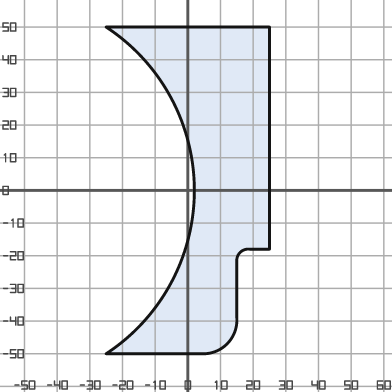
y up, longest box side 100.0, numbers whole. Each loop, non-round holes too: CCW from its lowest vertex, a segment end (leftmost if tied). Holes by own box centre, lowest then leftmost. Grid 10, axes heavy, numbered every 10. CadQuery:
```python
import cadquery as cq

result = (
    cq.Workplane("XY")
    .moveTo(-25.0, -50.0)
    .lineTo(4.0, -50.0)
    .threePointArc((12.0, -47.0), (15.0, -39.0))
    .lineTo(15.0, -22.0)
    .threePointArc((16.0, -19.0), (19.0, -18.0))
    .lineTo(25.0, -18.0)
    .lineTo(25.0, 50.0)
    .lineTo(-25.0, 50.0)
    .threePointArc((2.0, 0.0), (-25.0, -50.0))
    .close()
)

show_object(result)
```